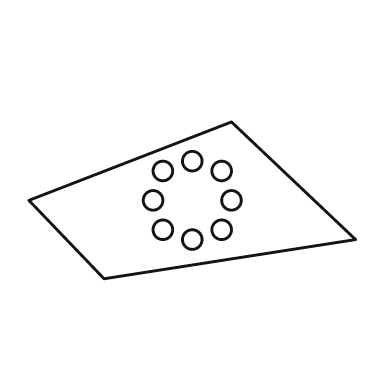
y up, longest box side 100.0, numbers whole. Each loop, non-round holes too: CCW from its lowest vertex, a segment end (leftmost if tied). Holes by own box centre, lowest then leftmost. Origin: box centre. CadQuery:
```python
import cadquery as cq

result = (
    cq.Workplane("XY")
    .moveTo(-27.0, -24.0)
    .lineTo(50.0, -12.0)
    .lineTo(12.0, 24.0)
    .lineTo(-50.0, 0.0)
    .close()
    .moveTo(0.0, -12.0)
    .circle(3.0)
    .moveTo(-9.0, -9.0)
    .circle(3.0)
    .moveTo(9.0, -9.0)
    .circle(3.0)
    .moveTo(-12.0, 0.0)
    .circle(3.0)
    .moveTo(12.0, 0.0)
    .circle(3.0)
    .moveTo(-9.0, 9.0)
    .circle(3.0)
    .moveTo(9.0, 9.0)
    .circle(3.0)
    .moveTo(0.0, 12.0)
    .circle(3.0)
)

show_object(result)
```